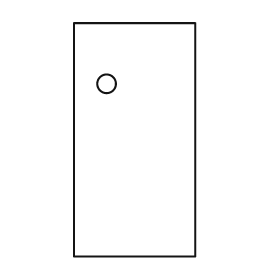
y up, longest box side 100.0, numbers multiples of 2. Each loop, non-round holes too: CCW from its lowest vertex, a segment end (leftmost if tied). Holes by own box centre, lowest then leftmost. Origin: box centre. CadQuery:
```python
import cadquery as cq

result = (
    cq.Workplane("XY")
    .moveTo(-26.0, -50.0)
    .lineTo(26.0, -50.0)
    .lineTo(26.0, 50.0)
    .lineTo(-26.0, 50.0)
    .close()
    .moveTo(-12.0, 24.0)
    .circle(4.0)
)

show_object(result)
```